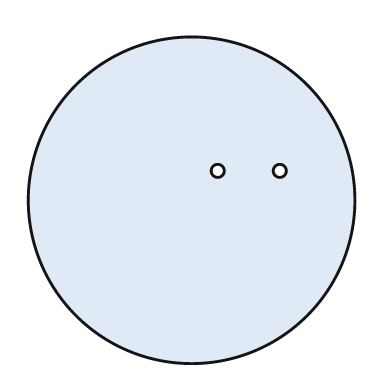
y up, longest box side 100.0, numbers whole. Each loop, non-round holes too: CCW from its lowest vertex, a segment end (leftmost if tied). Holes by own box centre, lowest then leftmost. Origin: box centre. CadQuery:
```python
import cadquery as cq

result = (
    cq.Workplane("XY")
    .moveTo(0.0, 0.0)
    .circle(50.0)
    .moveTo(8.0, 9.0)
    .circle(2.0)
    .moveTo(27.0, 9.0)
    .circle(2.0)
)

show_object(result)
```